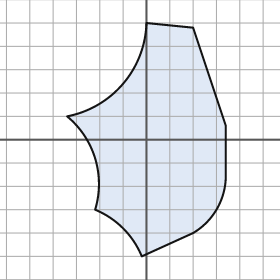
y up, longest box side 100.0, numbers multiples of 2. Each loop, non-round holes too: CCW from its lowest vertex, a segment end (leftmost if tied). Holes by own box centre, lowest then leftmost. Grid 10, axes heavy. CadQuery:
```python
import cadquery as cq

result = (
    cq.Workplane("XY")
    .moveTo(-2.0, -50.0)
    .lineTo(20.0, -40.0)
    .threePointArc((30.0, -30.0), (34.0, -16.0))
    .lineTo(34.0, 6.0)
    .lineTo(20.0, 48.0)
    .lineTo(0.0, 50.0)
    .threePointArc((-10.0, 24.0), (-34.0, 10.0))
    .threePointArc((-22.0, -8.0), (-22.0, -30.0))
    .threePointArc((-10.0, -38.0), (-2.0, -50.0))
    .close()
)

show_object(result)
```